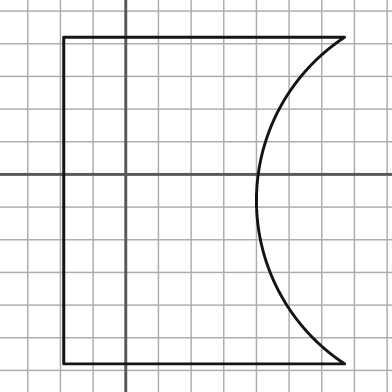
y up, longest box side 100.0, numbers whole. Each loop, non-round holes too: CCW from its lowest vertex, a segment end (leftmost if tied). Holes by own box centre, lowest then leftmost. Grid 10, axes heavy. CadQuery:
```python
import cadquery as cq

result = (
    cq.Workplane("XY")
    .moveTo(-19.0, -58.0)
    .lineTo(67.0, -58.0)
    .threePointArc((40.0, -8.0), (67.0, 42.0))
    .lineTo(-19.0, 42.0)
    .close()
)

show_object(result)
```